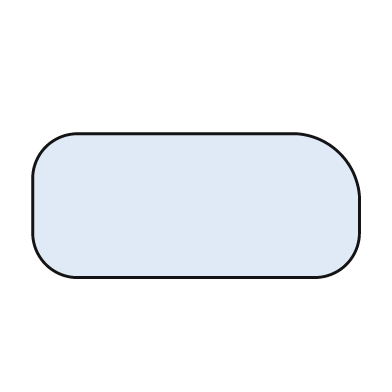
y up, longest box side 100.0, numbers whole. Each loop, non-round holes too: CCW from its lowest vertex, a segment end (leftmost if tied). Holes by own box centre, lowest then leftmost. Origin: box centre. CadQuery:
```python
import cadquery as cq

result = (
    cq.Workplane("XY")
    .moveTo(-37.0, -22.0)
    .lineTo(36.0, -22.0)
    .threePointArc((46.0, -18.0), (50.0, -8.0))
    .lineTo(50.0, 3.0)
    .threePointArc((44.0, 16.0), (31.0, 22.0))
    .lineTo(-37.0, 22.0)
    .threePointArc((-46.0, 18.0), (-50.0, 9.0))
    .lineTo(-50.0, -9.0)
    .threePointArc((-46.0, -18.0), (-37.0, -22.0))
    .close()
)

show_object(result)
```